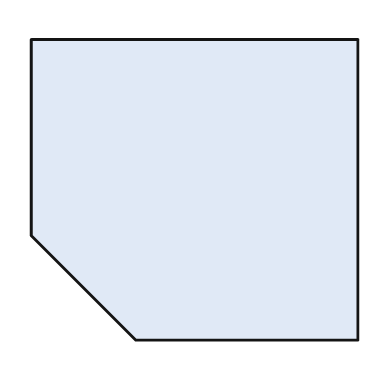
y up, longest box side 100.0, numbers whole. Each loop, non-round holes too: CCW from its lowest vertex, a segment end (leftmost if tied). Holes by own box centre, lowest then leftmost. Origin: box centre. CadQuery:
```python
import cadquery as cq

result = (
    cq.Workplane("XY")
    .moveTo(-18.0, -46.0)
    .lineTo(50.0, -46.0)
    .lineTo(50.0, 46.0)
    .lineTo(-50.0, 46.0)
    .lineTo(-50.0, -14.0)
    .close()
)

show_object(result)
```